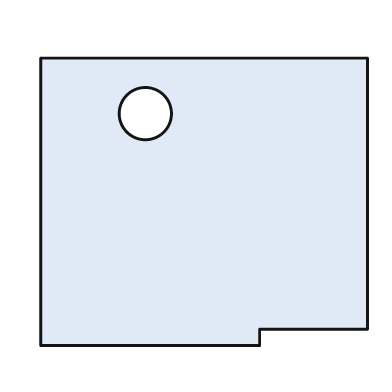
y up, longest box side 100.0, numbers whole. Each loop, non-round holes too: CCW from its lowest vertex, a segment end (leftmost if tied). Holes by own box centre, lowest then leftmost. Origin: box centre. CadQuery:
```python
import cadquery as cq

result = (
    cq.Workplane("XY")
    .moveTo(-50.0, -44.0)
    .lineTo(17.0, -44.0)
    .lineTo(17.0, -39.0)
    .lineTo(50.0, -39.0)
    .lineTo(50.0, 44.0)
    .lineTo(-50.0, 44.0)
    .close()
    .moveTo(-18.0, 27.0)
    .circle(8.0)
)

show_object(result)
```